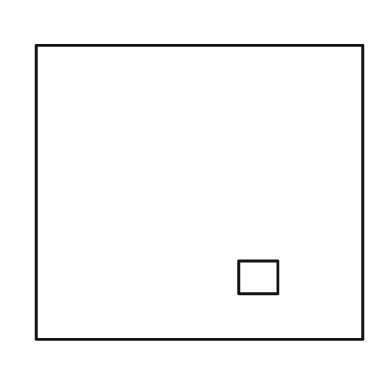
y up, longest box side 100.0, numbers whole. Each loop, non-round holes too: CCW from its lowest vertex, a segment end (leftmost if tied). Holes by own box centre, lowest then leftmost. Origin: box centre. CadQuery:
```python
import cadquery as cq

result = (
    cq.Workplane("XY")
    .moveTo(-50.0, -45.0)
    .lineTo(50.0, -45.0)
    .lineTo(50.0, 45.0)
    .lineTo(-50.0, 45.0)
    .close()
    .moveTo(12.0, -31.0)
    .lineTo(24.0, -31.0)
    .lineTo(24.0, -21.0)
    .lineTo(12.0, -21.0)
    .close()
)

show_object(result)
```